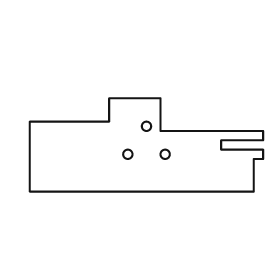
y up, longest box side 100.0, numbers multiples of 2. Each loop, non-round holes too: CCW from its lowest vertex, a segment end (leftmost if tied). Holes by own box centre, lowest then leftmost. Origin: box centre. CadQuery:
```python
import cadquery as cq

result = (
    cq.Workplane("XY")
    .moveTo(-50.0, -20.0)
    .lineTo(46.0, -20.0)
    .lineTo(46.0, -6.0)
    .lineTo(50.0, -6.0)
    .lineTo(50.0, -2.0)
    .lineTo(32.0, -2.0)
    .lineTo(32.0, 2.0)
    .lineTo(50.0, 2.0)
    .lineTo(50.0, 6.0)
    .lineTo(6.0, 6.0)
    .lineTo(6.0, 20.0)
    .lineTo(-16.0, 20.0)
    .lineTo(-16.0, 10.0)
    .lineTo(-50.0, 10.0)
    .close()
    .moveTo(-8.0, -4.0)
    .circle(2.0)
    .moveTo(8.0, -4.0)
    .circle(2.0)
    .moveTo(0.0, 8.0)
    .circle(2.0)
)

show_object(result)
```